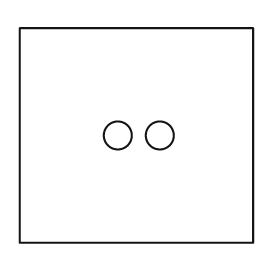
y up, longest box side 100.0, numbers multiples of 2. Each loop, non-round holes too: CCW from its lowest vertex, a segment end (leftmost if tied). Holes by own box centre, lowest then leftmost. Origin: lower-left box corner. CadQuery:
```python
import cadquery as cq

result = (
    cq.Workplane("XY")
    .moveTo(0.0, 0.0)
    .lineTo(100.0, 0.0)
    .lineTo(100.0, 92.0)
    .lineTo(0.0, 92.0)
    .close()
    .moveTo(42.0, 46.0)
    .circle(6.0)
    .moveTo(60.0, 46.0)
    .circle(6.0)
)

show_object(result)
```